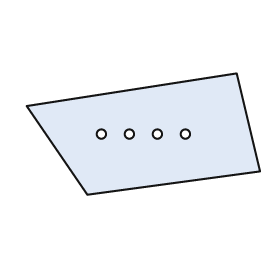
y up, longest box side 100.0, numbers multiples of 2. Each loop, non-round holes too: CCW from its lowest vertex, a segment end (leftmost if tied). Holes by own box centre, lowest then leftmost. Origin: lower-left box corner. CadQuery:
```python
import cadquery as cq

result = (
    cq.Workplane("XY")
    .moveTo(26.0, 0.0)
    .lineTo(100.0, 10.0)
    .lineTo(90.0, 52.0)
    .lineTo(0.0, 38.0)
    .close()
    .moveTo(32.0, 26.0)
    .circle(2.0)
    .moveTo(44.0, 26.0)
    .circle(2.0)
    .moveTo(56.0, 26.0)
    .circle(2.0)
    .moveTo(68.0, 26.0)
    .circle(2.0)
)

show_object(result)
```